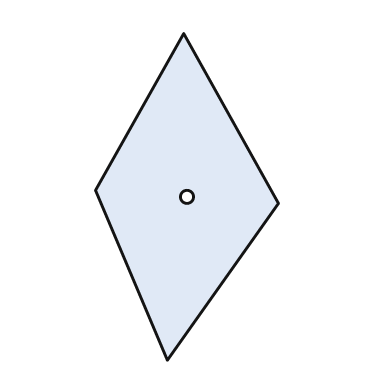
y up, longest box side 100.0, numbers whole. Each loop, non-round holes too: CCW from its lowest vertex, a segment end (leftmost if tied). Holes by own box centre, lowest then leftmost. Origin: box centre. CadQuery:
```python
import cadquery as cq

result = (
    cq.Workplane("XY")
    .moveTo(-6.0, -50.0)
    .lineTo(28.0, -2.0)
    .lineTo(-1.0, 50.0)
    .lineTo(-28.0, 2.0)
    .close()
    .moveTo(0.0, 0.0)
    .circle(2.0)
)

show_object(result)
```